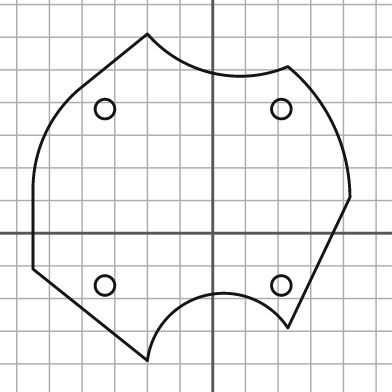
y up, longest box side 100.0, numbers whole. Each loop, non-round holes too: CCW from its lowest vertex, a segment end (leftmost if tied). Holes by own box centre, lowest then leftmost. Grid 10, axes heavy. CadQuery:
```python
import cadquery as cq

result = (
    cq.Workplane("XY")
    .moveTo(-20.0, -39.0)
    .threePointArc((-2.0, -19.0), (23.0, -29.0))
    .lineTo(42.0, 11.0)
    .threePointArc((37.0, 33.0), (23.0, 51.0))
    .threePointArc((0.0, 49.0), (-20.0, 61.0))
    .lineTo(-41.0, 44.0)
    .threePointArc((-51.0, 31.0), (-55.0, 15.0))
    .lineTo(-55.0, -11.0)
    .close()
    .moveTo(-33.0, -16.0)
    .circle(3.0)
    .moveTo(21.0, -16.0)
    .circle(3.0)
    .moveTo(-33.0, 38.0)
    .circle(3.0)
    .moveTo(21.0, 38.0)
    .circle(3.0)
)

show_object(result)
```